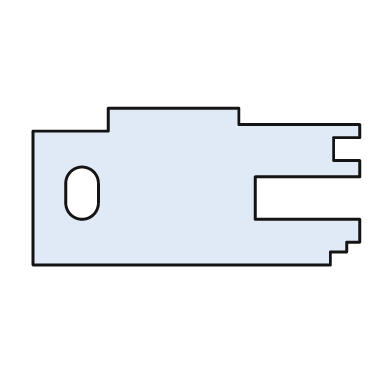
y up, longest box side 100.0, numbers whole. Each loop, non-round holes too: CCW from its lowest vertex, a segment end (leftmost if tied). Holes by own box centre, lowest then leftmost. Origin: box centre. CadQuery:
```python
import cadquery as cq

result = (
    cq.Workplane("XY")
    .moveTo(-50.0, -24.0)
    .lineTo(41.0, -24.0)
    .lineTo(41.0, -20.0)
    .lineTo(46.0, -20.0)
    .lineTo(46.0, -17.0)
    .lineTo(50.0, -17.0)
    .lineTo(50.0, -10.0)
    .lineTo(18.0, -10.0)
    .lineTo(18.0, 3.0)
    .lineTo(50.0, 3.0)
    .lineTo(50.0, 8.0)
    .lineTo(42.0, 8.0)
    .lineTo(42.0, 15.0)
    .lineTo(50.0, 15.0)
    .lineTo(50.0, 19.0)
    .lineTo(13.0, 19.0)
    .lineTo(13.0, 24.0)
    .lineTo(-27.0, 24.0)
    .lineTo(-27.0, 17.0)
    .lineTo(-50.0, 17.0)
    .close()
    .moveTo(-40.0, -5.0)
    .threePointArc((-35.0, -10.0), (-30.0, -5.0))
    .lineTo(-30.0, 1.0)
    .threePointArc((-35.0, 6.0), (-40.0, 1.0))
    .close()
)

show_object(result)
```